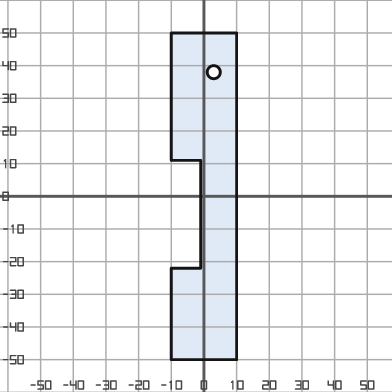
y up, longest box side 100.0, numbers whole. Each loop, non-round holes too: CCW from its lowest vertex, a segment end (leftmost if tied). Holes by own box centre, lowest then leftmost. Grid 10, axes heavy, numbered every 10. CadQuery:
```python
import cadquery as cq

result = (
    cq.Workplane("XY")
    .moveTo(-10.0, -50.0)
    .lineTo(10.0, -50.0)
    .lineTo(10.0, 50.0)
    .lineTo(-10.0, 50.0)
    .lineTo(-10.0, 11.0)
    .lineTo(-1.0, 11.0)
    .lineTo(-1.0, -22.0)
    .lineTo(-10.0, -22.0)
    .close()
    .moveTo(3.0, 38.0)
    .circle(2.0)
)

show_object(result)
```